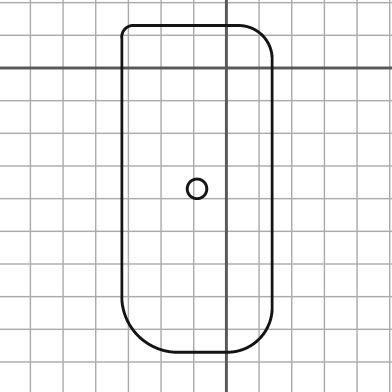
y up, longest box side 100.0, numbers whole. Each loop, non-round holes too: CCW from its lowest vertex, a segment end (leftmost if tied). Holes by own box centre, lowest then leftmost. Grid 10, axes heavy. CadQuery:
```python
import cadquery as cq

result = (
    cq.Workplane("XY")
    .moveTo(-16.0, -87.0)
    .lineTo(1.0, -87.0)
    .threePointArc((10.0, -83.0), (14.0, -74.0))
    .lineTo(14.0, 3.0)
    .threePointArc((11.0, 10.0), (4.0, 13.0))
    .lineTo(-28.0, 13.0)
    .threePointArc((-31.0, 12.0), (-32.0, 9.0))
    .lineTo(-32.0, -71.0)
    .threePointArc((-27.0, -82.0), (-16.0, -87.0))
    .close()
    .moveTo(-9.0, -37.0)
    .circle(3.0)
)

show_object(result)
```